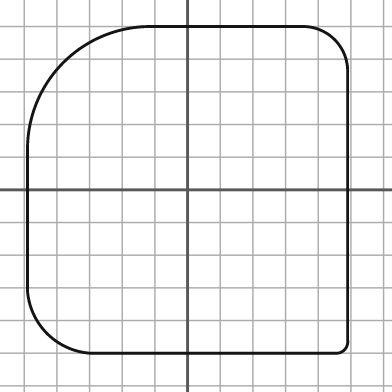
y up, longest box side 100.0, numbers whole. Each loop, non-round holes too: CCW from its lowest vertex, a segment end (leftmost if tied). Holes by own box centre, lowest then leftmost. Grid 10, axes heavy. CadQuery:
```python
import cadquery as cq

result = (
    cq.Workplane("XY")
    .moveTo(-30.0, -50.0)
    .lineTo(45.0, -50.0)
    .threePointArc((48.0, -49.0), (49.0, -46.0))
    .lineTo(49.0, 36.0)
    .threePointArc((45.0, 46.0), (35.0, 50.0))
    .lineTo(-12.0, 50.0)
    .threePointArc((-38.0, 39.0), (-49.0, 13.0))
    .lineTo(-49.0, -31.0)
    .threePointArc((-43.0, -44.0), (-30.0, -50.0))
    .close()
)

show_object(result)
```